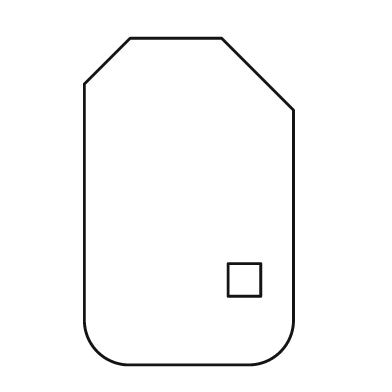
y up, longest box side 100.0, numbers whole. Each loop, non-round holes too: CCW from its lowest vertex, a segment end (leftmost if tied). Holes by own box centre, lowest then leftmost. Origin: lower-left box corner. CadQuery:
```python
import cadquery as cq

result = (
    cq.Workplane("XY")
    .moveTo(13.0, 0.0)
    .lineTo(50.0, 0.0)
    .threePointArc((60.0, 4.0), (64.0, 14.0))
    .lineTo(64.0, 78.0)
    .lineTo(42.0, 100.0)
    .lineTo(14.0, 100.0)
    .lineTo(0.0, 86.0)
    .lineTo(0.0, 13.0)
    .threePointArc((4.0, 4.0), (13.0, 0.0))
    .close()
    .moveTo(44.0, 21.0)
    .lineTo(54.0, 21.0)
    .lineTo(54.0, 31.0)
    .lineTo(44.0, 31.0)
    .close()
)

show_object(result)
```